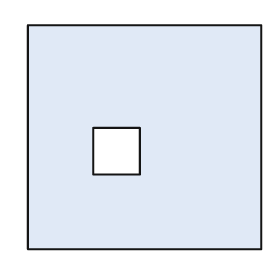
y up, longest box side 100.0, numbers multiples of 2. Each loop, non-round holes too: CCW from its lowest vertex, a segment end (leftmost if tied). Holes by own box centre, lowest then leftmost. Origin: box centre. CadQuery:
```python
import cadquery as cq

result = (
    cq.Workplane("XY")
    .moveTo(-50.0, -48.0)
    .lineTo(50.0, -48.0)
    .lineTo(50.0, 48.0)
    .lineTo(-50.0, 48.0)
    .close()
    .moveTo(-22.0, -16.0)
    .lineTo(-2.0, -16.0)
    .lineTo(-2.0, 4.0)
    .lineTo(-22.0, 4.0)
    .close()
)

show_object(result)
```